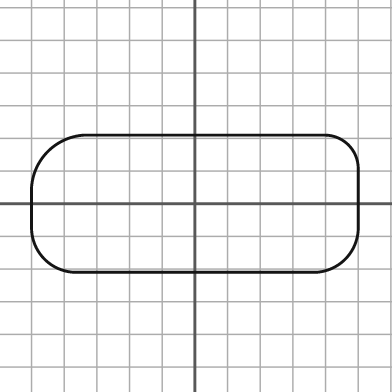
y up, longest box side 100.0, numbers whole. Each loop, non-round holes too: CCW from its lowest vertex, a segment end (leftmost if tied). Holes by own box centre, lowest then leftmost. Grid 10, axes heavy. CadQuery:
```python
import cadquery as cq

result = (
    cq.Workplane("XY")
    .moveTo(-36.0, -21.0)
    .lineTo(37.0, -21.0)
    .threePointArc((46.0, -17.0), (50.0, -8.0))
    .lineTo(50.0, 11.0)
    .threePointArc((47.0, 18.0), (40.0, 21.0))
    .lineTo(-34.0, 21.0)
    .threePointArc((-45.0, 16.0), (-50.0, 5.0))
    .lineTo(-50.0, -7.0)
    .threePointArc((-46.0, -17.0), (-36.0, -21.0))
    .close()
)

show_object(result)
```